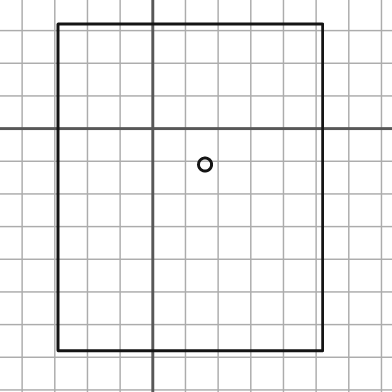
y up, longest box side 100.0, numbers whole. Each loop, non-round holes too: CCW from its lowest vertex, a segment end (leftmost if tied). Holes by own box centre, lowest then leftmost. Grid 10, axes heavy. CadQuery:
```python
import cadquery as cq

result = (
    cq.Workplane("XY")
    .moveTo(-29.0, -68.0)
    .lineTo(52.0, -68.0)
    .lineTo(52.0, 32.0)
    .lineTo(-29.0, 32.0)
    .close()
    .moveTo(16.0, -11.0)
    .circle(2.0)
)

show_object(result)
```